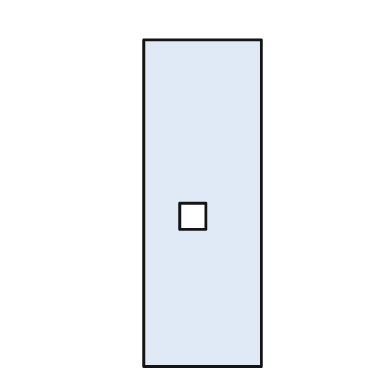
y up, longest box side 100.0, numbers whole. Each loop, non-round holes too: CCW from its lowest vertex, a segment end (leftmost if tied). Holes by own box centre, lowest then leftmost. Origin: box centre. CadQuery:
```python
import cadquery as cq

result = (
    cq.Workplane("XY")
    .moveTo(-18.0, -50.0)
    .lineTo(18.0, -50.0)
    .lineTo(18.0, 50.0)
    .lineTo(-18.0, 50.0)
    .close()
    .moveTo(-7.0, -8.0)
    .lineTo(1.0, -8.0)
    .lineTo(1.0, 0.0)
    .lineTo(-7.0, 0.0)
    .close()
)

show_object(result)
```